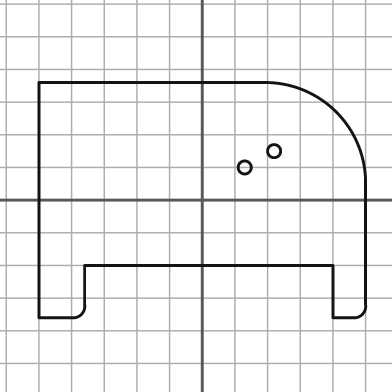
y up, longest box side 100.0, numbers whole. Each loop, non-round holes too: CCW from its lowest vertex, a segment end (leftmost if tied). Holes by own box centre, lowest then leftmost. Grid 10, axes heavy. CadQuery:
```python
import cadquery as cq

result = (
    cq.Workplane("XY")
    .moveTo(-50.0, -36.0)
    .lineTo(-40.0, -36.0)
    .threePointArc((-37.0, -35.0), (-36.0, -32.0))
    .lineTo(-36.0, -20.0)
    .lineTo(40.0, -20.0)
    .lineTo(40.0, -36.0)
    .lineTo(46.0, -36.0)
    .threePointArc((49.0, -35.0), (50.0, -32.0))
    .lineTo(50.0, 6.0)
    .threePointArc((41.0, 27.0), (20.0, 36.0))
    .lineTo(-50.0, 36.0)
    .close()
    .moveTo(13.0, 10.0)
    .circle(2.0)
    .moveTo(22.0, 15.0)
    .circle(2.0)
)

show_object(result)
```